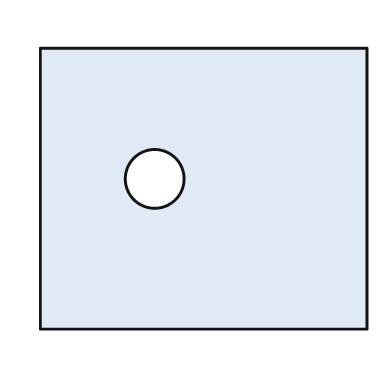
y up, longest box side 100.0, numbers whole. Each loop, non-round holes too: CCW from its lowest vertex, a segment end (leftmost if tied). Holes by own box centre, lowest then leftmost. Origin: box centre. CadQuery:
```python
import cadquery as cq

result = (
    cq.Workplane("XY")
    .moveTo(-50.0, -43.0)
    .lineTo(50.0, -43.0)
    .lineTo(50.0, 43.0)
    .lineTo(-50.0, 43.0)
    .close()
    .moveTo(-15.0, 3.0)
    .circle(9.0)
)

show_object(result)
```